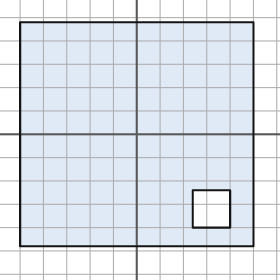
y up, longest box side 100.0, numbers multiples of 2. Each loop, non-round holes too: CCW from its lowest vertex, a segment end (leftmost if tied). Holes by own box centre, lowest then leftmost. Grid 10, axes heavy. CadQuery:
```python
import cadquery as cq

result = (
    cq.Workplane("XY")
    .moveTo(-50.0, -48.0)
    .lineTo(50.0, -48.0)
    .lineTo(50.0, 48.0)
    .lineTo(-50.0, 48.0)
    .close()
    .moveTo(24.0, -40.0)
    .lineTo(40.0, -40.0)
    .lineTo(40.0, -24.0)
    .lineTo(24.0, -24.0)
    .close()
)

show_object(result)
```